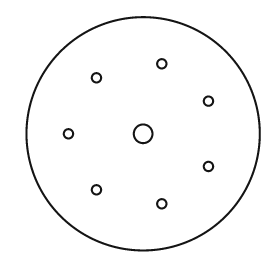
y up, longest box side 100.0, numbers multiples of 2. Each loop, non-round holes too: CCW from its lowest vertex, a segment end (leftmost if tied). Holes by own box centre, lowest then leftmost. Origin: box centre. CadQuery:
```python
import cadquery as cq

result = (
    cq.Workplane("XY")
    .moveTo(0.0, 0.0)
    .circle(50.0)
    .moveTo(8.0, -30.0)
    .circle(2.0)
    .moveTo(-20.0, -24.0)
    .circle(2.0)
    .moveTo(28.0, -14.0)
    .circle(2.0)
    .moveTo(-32.0, 0.0)
    .circle(2.0)
    .moveTo(0.0, 0.0)
    .circle(4.0)
    .moveTo(28.0, 14.0)
    .circle(2.0)
    .moveTo(-20.0, 24.0)
    .circle(2.0)
    .moveTo(8.0, 30.0)
    .circle(2.0)
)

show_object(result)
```